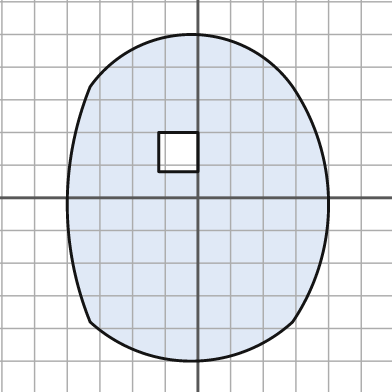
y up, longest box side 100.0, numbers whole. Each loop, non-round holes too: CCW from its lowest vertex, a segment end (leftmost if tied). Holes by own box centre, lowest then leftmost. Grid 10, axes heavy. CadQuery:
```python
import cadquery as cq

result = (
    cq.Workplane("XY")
    .moveTo(-33.0, -38.0)
    .threePointArc((-2.0, -50.0), (29.0, -38.0))
    .threePointArc((40.0, -2.0), (29.0, 34.0))
    .threePointArc((-2.0, 50.0), (-33.0, 34.0))
    .threePointArc((-40.0, -2.0), (-33.0, -38.0))
    .close()
    .moveTo(-12.0, 8.0)
    .lineTo(0.0, 8.0)
    .lineTo(0.0, 20.0)
    .lineTo(-12.0, 20.0)
    .close()
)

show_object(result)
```